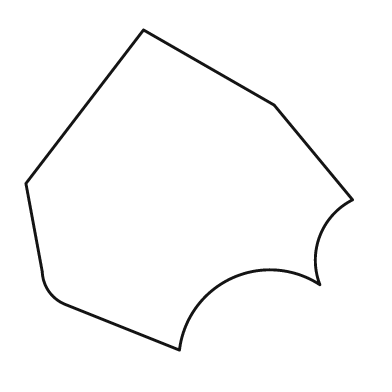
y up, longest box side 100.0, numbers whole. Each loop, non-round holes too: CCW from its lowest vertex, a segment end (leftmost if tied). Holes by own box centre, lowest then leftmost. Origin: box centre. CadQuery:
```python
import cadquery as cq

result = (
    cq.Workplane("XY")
    .moveTo(-3.0, -49.0)
    .threePointArc((13.0, -27.0), (40.0, -29.0))
    .threePointArc((40.0, -14.0), (50.0, -3.0))
    .lineTo(26.0, 26.0)
    .lineTo(-14.0, 49.0)
    .lineTo(-50.0, 2.0)
    .lineTo(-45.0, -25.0)
    .threePointArc((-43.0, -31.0), (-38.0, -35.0))
    .close()
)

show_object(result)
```